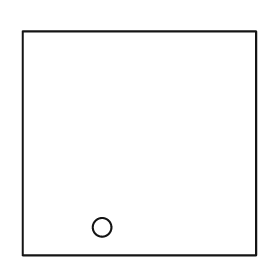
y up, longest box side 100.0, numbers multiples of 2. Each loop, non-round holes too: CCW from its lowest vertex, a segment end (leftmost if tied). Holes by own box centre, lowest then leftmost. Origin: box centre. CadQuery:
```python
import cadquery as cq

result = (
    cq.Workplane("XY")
    .moveTo(-50.0, -48.0)
    .lineTo(50.0, -48.0)
    .lineTo(50.0, 48.0)
    .lineTo(-50.0, 48.0)
    .close()
    .moveTo(-16.0, -36.0)
    .circle(4.0)
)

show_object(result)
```